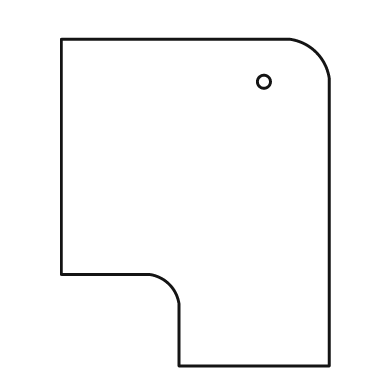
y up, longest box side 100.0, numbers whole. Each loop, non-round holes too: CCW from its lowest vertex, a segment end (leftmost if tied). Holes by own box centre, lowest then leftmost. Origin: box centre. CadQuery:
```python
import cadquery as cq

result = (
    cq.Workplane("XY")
    .moveTo(-5.0, -50.0)
    .lineTo(41.0, -50.0)
    .lineTo(41.0, 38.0)
    .threePointArc((37.0, 46.0), (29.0, 50.0))
    .lineTo(-41.0, 50.0)
    .lineTo(-41.0, -22.0)
    .lineTo(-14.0, -22.0)
    .threePointArc((-8.0, -25.0), (-5.0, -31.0))
    .close()
    .moveTo(21.0, 37.0)
    .circle(2.0)
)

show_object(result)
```